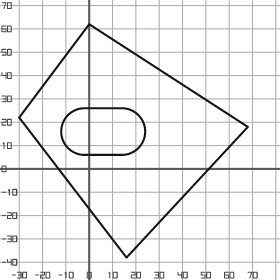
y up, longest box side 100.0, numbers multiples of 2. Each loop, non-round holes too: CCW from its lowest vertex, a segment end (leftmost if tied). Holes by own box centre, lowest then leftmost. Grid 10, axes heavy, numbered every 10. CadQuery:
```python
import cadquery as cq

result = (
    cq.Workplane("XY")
    .moveTo(16.0, -38.0)
    .lineTo(68.0, 18.0)
    .lineTo(0.0, 62.0)
    .lineTo(-30.0, 22.0)
    .close()
    .moveTo(-2.0, 6.0)
    .lineTo(14.0, 6.0)
    .threePointArc((24.0, 16.0), (14.0, 26.0))
    .lineTo(-2.0, 26.0)
    .threePointArc((-12.0, 16.0), (-2.0, 6.0))
    .close()
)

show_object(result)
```